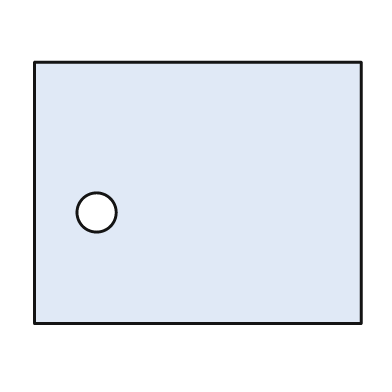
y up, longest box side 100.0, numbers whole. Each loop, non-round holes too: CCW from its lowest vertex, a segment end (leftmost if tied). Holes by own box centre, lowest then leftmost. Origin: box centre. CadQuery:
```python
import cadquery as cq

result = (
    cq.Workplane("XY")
    .moveTo(-50.0, -40.0)
    .lineTo(50.0, -40.0)
    .lineTo(50.0, 40.0)
    .lineTo(-50.0, 40.0)
    .close()
    .moveTo(-31.0, -6.0)
    .circle(6.0)
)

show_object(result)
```